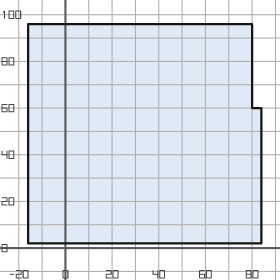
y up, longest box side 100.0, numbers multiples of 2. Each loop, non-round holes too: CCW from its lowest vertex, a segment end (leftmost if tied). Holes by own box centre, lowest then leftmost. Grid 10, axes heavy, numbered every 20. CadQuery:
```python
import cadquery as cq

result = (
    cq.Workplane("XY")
    .moveTo(-16.0, 2.0)
    .lineTo(84.0, 2.0)
    .lineTo(84.0, 60.0)
    .lineTo(80.0, 60.0)
    .lineTo(80.0, 96.0)
    .lineTo(-16.0, 96.0)
    .close()
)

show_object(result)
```